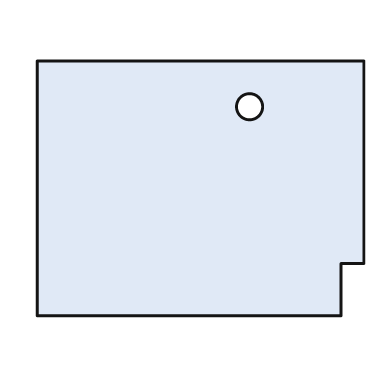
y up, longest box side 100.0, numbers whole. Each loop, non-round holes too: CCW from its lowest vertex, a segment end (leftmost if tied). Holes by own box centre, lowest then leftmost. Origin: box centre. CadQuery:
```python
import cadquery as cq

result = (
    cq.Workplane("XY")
    .moveTo(-50.0, -39.0)
    .lineTo(43.0, -39.0)
    .lineTo(43.0, -23.0)
    .lineTo(50.0, -23.0)
    .lineTo(50.0, 39.0)
    .lineTo(-50.0, 39.0)
    .close()
    .moveTo(15.0, 25.0)
    .circle(4.0)
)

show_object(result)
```